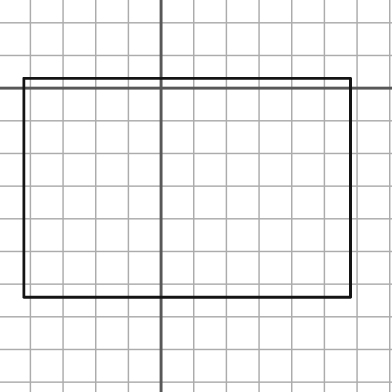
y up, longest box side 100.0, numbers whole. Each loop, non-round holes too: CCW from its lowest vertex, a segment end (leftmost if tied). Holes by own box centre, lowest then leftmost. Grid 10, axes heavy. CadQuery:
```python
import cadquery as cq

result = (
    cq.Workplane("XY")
    .moveTo(-42.0, -64.0)
    .lineTo(58.0, -64.0)
    .lineTo(58.0, 3.0)
    .lineTo(-42.0, 3.0)
    .close()
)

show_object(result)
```